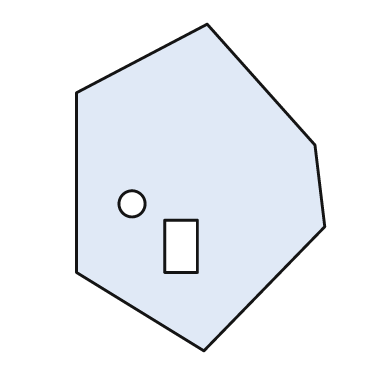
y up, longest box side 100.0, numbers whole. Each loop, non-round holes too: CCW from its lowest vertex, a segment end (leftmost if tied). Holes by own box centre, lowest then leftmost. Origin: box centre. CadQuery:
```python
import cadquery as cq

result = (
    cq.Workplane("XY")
    .moveTo(1.0, -50.0)
    .lineTo(38.0, -12.0)
    .lineTo(35.0, 13.0)
    .lineTo(2.0, 50.0)
    .lineTo(-38.0, 29.0)
    .lineTo(-38.0, -26.0)
    .close()
    .moveTo(-11.0, -26.0)
    .lineTo(-1.0, -26.0)
    .lineTo(-1.0, -10.0)
    .lineTo(-11.0, -10.0)
    .close()
    .moveTo(-21.0, -5.0)
    .circle(4.0)
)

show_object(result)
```